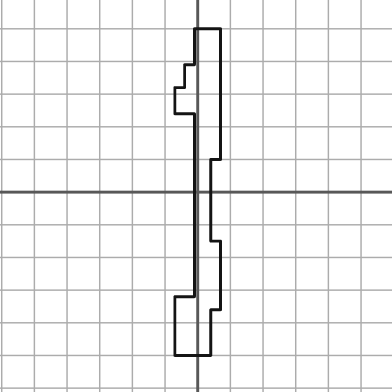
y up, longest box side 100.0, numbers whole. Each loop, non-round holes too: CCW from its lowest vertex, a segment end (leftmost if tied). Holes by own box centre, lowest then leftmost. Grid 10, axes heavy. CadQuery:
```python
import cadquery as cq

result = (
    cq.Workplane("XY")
    .moveTo(-7.0, -50.0)
    .lineTo(4.0, -50.0)
    .lineTo(4.0, -36.0)
    .lineTo(7.0, -36.0)
    .lineTo(7.0, -15.0)
    .lineTo(4.0, -15.0)
    .lineTo(4.0, 10.0)
    .lineTo(7.0, 10.0)
    .lineTo(7.0, 50.0)
    .lineTo(-1.0, 50.0)
    .lineTo(-1.0, 39.0)
    .lineTo(-4.0, 39.0)
    .lineTo(-4.0, 32.0)
    .lineTo(-7.0, 32.0)
    .lineTo(-7.0, 24.0)
    .lineTo(-1.0, 24.0)
    .lineTo(-1.0, -32.0)
    .lineTo(-7.0, -32.0)
    .close()
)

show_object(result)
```